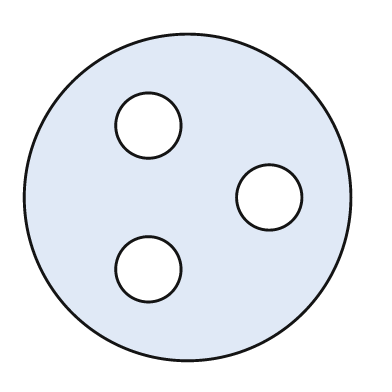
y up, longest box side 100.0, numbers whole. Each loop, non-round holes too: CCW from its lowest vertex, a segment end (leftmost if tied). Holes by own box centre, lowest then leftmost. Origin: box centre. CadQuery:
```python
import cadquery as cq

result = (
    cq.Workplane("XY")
    .moveTo(0.0, 0.0)
    .circle(50.0)
    .moveTo(-12.0, -22.0)
    .circle(10.0)
    .moveTo(25.0, 0.0)
    .circle(10.0)
    .moveTo(-12.0, 22.0)
    .circle(10.0)
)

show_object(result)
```